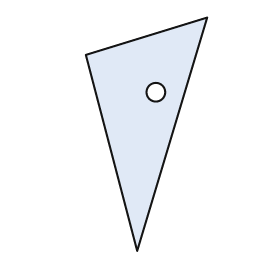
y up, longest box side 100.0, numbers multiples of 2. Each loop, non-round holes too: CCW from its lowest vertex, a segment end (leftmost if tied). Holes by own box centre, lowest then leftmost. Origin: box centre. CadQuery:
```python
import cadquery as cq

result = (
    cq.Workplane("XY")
    .moveTo(-4.0, -50.0)
    .lineTo(26.0, 50.0)
    .lineTo(-26.0, 34.0)
    .close()
    .moveTo(4.0, 18.0)
    .circle(4.0)
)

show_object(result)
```